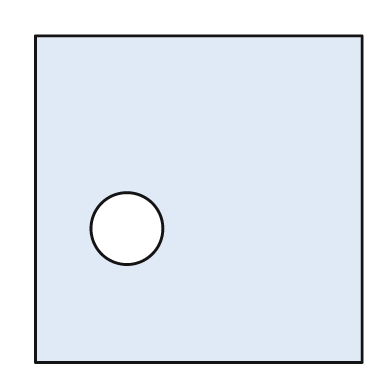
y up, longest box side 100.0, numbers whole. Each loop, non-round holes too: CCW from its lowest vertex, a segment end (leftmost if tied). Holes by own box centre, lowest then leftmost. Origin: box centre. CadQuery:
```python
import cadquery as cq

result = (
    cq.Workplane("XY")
    .moveTo(-50.0, -50.0)
    .lineTo(50.0, -50.0)
    .lineTo(50.0, 50.0)
    .lineTo(-50.0, 50.0)
    .close()
    .moveTo(-22.0, -9.0)
    .circle(11.0)
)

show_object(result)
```